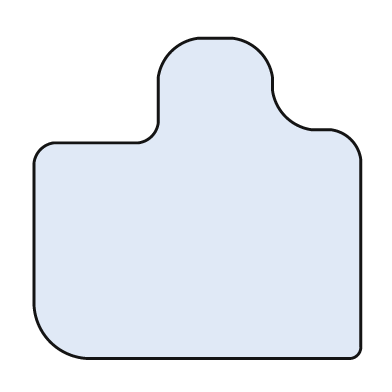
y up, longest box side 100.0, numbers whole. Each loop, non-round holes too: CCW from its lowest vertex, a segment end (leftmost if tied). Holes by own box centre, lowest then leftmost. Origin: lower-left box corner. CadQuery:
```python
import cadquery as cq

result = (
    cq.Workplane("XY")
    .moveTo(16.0, 0.0)
    .lineTo(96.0, 0.0)
    .threePointArc((99.0, 1.0), (100.0, 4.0))
    .lineTo(100.0, 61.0)
    .threePointArc((97.0, 67.0), (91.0, 70.0))
    .lineTo(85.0, 70.0)
    .threePointArc((77.0, 74.0), (73.0, 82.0))
    .lineTo(73.0, 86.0)
    .threePointArc((69.0, 94.0), (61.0, 98.0))
    .lineTo(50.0, 98.0)
    .threePointArc((42.0, 94.0), (38.0, 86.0))
    .lineTo(38.0, 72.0)
    .threePointArc((36.0, 68.0), (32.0, 66.0))
    .lineTo(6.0, 66.0)
    .threePointArc((2.0, 64.0), (0.0, 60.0))
    .lineTo(0.0, 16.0)
    .threePointArc((5.0, 5.0), (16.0, 0.0))
    .close()
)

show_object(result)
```